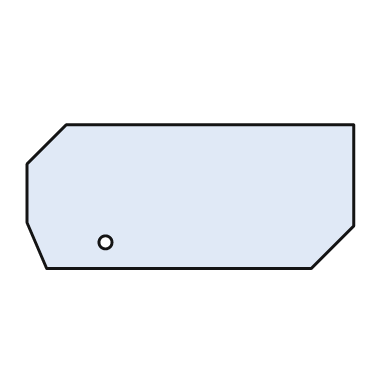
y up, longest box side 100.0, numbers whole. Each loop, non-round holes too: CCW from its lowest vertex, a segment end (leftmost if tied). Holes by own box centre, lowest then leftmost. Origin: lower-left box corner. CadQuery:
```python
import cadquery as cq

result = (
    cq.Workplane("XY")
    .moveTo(6.0, 0.0)
    .lineTo(87.0, 0.0)
    .lineTo(100.0, 13.0)
    .lineTo(100.0, 44.0)
    .lineTo(12.0, 44.0)
    .lineTo(0.0, 32.0)
    .lineTo(0.0, 14.0)
    .close()
    .moveTo(24.0, 8.0)
    .circle(2.0)
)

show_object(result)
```